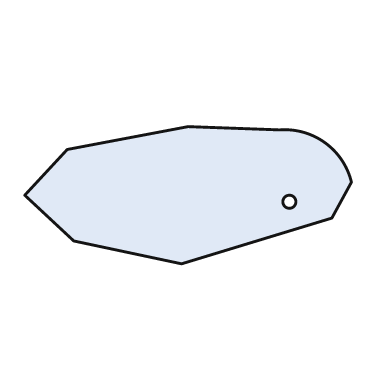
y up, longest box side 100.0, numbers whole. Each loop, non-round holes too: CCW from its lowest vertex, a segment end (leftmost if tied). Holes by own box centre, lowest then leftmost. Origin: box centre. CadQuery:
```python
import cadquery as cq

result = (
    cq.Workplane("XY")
    .moveTo(-2.0, -21.0)
    .lineTo(44.0, -7.0)
    .lineTo(50.0, 4.0)
    .threePointArc((42.0, 16.0), (28.0, 20.0))
    .lineTo(0.0, 21.0)
    .lineTo(-37.0, 14.0)
    .lineTo(-50.0, 0.0)
    .lineTo(-35.0, -14.0)
    .close()
    .moveTo(31.0, -2.0)
    .circle(2.0)
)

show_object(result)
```